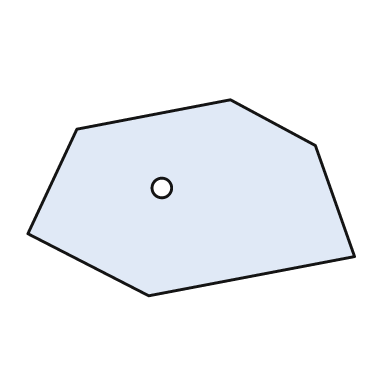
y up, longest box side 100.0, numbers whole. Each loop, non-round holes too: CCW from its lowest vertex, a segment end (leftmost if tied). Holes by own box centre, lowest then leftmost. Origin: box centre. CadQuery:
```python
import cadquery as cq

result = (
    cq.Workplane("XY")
    .moveTo(-13.0, -30.0)
    .lineTo(50.0, -18.0)
    .lineTo(38.0, 16.0)
    .lineTo(12.0, 30.0)
    .lineTo(-35.0, 21.0)
    .lineTo(-50.0, -11.0)
    .close()
    .moveTo(-9.0, 3.0)
    .circle(3.0)
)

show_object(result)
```